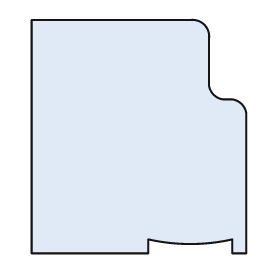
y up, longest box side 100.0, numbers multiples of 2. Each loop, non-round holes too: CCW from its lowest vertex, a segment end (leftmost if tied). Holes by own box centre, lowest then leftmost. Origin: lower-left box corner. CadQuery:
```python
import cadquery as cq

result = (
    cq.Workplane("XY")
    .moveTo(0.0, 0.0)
    .lineTo(50.0, 0.0)
    .lineTo(50.0, 6.0)
    .threePointArc((68.0, 4.0), (86.0, 6.0))
    .lineTo(86.0, 0.0)
    .lineTo(92.0, 0.0)
    .lineTo(92.0, 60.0)
    .threePointArc((90.0, 64.0), (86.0, 66.0))
    .lineTo(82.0, 66.0)
    .threePointArc((78.0, 68.0), (76.0, 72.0))
    .lineTo(76.0, 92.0)
    .threePointArc((74.0, 98.0), (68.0, 100.0))
    .lineTo(0.0, 100.0)
    .close()
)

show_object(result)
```